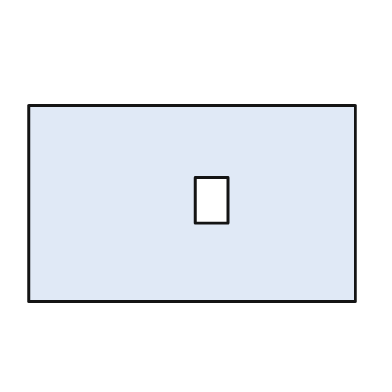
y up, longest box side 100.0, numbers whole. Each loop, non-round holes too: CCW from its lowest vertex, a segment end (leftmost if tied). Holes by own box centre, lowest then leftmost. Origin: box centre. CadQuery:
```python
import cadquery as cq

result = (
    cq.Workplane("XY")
    .moveTo(-50.0, -30.0)
    .lineTo(50.0, -30.0)
    .lineTo(50.0, 30.0)
    .lineTo(-50.0, 30.0)
    .close()
    .moveTo(1.0, -6.0)
    .lineTo(11.0, -6.0)
    .lineTo(11.0, 8.0)
    .lineTo(1.0, 8.0)
    .close()
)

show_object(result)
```